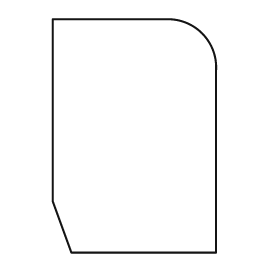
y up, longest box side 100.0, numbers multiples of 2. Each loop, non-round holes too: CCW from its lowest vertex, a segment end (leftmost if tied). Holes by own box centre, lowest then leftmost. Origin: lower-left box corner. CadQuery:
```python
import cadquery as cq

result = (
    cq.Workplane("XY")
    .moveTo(8.0, 0.0)
    .lineTo(70.0, 0.0)
    .lineTo(70.0, 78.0)
    .threePointArc((64.0, 94.0), (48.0, 100.0))
    .lineTo(0.0, 100.0)
    .lineTo(0.0, 22.0)
    .close()
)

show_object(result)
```